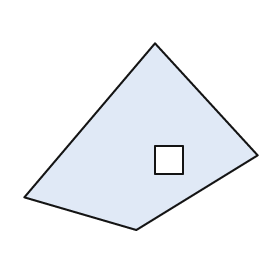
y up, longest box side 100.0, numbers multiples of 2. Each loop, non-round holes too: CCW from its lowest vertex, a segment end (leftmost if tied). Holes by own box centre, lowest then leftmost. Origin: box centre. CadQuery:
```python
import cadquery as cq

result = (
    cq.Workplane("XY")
    .moveTo(-2.0, -40.0)
    .lineTo(50.0, -8.0)
    .lineTo(6.0, 40.0)
    .lineTo(-50.0, -26.0)
    .close()
    .moveTo(6.0, -16.0)
    .lineTo(18.0, -16.0)
    .lineTo(18.0, -4.0)
    .lineTo(6.0, -4.0)
    .close()
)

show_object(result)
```